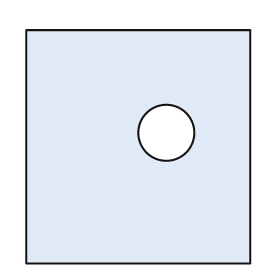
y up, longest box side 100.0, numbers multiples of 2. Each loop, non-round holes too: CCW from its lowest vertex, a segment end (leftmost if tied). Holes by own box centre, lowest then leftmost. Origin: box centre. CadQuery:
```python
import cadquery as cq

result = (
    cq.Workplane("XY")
    .moveTo(-48.0, -50.0)
    .lineTo(48.0, -50.0)
    .lineTo(48.0, 50.0)
    .lineTo(-48.0, 50.0)
    .close()
    .moveTo(12.0, 6.0)
    .circle(12.0)
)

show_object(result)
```